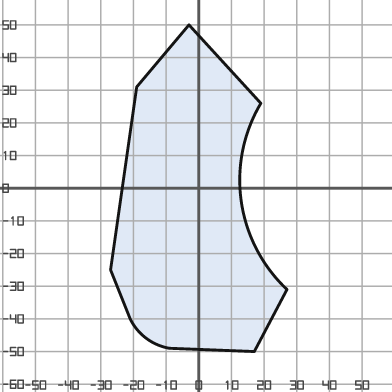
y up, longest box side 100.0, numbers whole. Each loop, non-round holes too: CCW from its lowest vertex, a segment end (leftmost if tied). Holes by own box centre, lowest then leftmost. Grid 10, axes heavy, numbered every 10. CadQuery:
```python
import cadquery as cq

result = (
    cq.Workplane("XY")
    .moveTo(17.0, -50.0)
    .lineTo(27.0, -31.0)
    .threePointArc((13.0, -4.0), (19.0, 26.0))
    .lineTo(-3.0, 50.0)
    .lineTo(-19.0, 31.0)
    .lineTo(-27.0, -25.0)
    .lineTo(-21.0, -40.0)
    .threePointArc((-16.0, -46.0), (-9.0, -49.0))
    .close()
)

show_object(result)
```